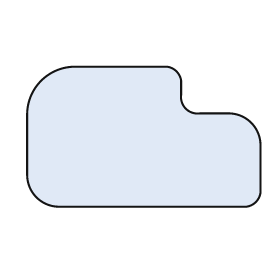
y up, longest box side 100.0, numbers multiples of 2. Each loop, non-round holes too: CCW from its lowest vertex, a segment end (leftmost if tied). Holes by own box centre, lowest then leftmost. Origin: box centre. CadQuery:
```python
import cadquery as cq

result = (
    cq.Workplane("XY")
    .moveTo(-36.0, -30.0)
    .lineTo(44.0, -30.0)
    .threePointArc((48.0, -28.0), (50.0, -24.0))
    .lineTo(50.0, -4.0)
    .threePointArc((46.0, 6.0), (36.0, 10.0))
    .lineTo(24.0, 10.0)
    .threePointArc((18.0, 12.0), (16.0, 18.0))
    .lineTo(16.0, 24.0)
    .threePointArc((14.0, 28.0), (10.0, 30.0))
    .lineTo(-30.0, 30.0)
    .threePointArc((-44.0, 24.0), (-50.0, 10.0))
    .lineTo(-50.0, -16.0)
    .threePointArc((-46.0, -26.0), (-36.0, -30.0))
    .close()
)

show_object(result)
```